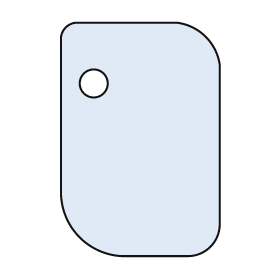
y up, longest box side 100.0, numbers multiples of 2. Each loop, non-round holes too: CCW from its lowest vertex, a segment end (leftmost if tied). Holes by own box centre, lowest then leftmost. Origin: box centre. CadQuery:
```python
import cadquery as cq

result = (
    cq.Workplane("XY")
    .moveTo(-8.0, -50.0)
    .lineTo(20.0, -50.0)
    .threePointArc((30.0, -46.0), (34.0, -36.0))
    .lineTo(34.0, 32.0)
    .threePointArc((28.0, 44.0), (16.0, 50.0))
    .lineTo(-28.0, 50.0)
    .threePointArc((-32.0, 48.0), (-34.0, 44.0))
    .lineTo(-34.0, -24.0)
    .threePointArc((-26.0, -42.0), (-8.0, -50.0))
    .close()
    .moveTo(-20.0, 24.0)
    .circle(6.0)
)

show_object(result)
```